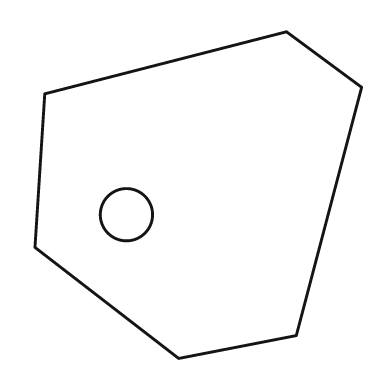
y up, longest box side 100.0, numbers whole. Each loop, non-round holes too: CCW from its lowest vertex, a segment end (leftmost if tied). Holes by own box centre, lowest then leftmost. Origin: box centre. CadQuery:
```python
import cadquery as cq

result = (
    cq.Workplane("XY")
    .moveTo(-6.0, -50.0)
    .lineTo(30.0, -43.0)
    .lineTo(50.0, 33.0)
    .lineTo(27.0, 50.0)
    .lineTo(-47.0, 31.0)
    .lineTo(-50.0, -16.0)
    .close()
    .moveTo(-22.0, -6.0)
    .circle(8.0)
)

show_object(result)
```